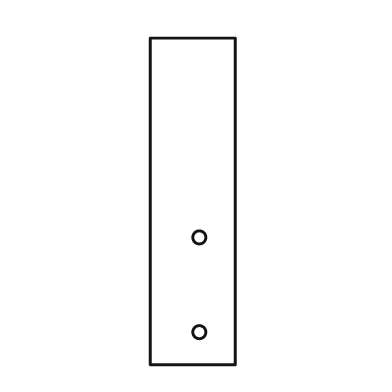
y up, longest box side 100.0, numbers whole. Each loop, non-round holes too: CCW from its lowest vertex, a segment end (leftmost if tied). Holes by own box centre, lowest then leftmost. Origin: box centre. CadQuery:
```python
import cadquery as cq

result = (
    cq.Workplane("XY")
    .moveTo(-13.0, -50.0)
    .lineTo(13.0, -50.0)
    .lineTo(13.0, 50.0)
    .lineTo(-13.0, 50.0)
    .close()
    .moveTo(2.0, -40.0)
    .circle(2.0)
    .moveTo(2.0, -11.0)
    .circle(2.0)
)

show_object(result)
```